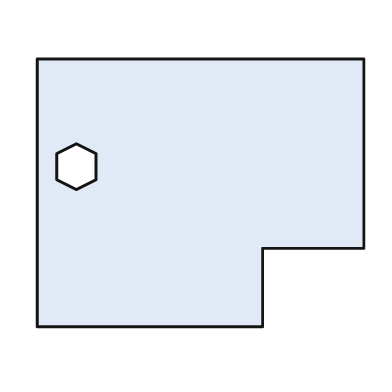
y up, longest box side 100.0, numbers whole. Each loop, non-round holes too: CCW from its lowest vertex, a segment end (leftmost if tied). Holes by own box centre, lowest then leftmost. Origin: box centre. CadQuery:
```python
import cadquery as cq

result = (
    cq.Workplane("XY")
    .moveTo(-50.0, -41.0)
    .lineTo(19.0, -41.0)
    .lineTo(19.0, -17.0)
    .lineTo(50.0, -17.0)
    .lineTo(50.0, 41.0)
    .lineTo(-50.0, 41.0)
    .close()
    .moveTo(-38.0, 1.0)
    .lineTo(-32.0, 4.0)
    .lineTo(-32.0, 12.0)
    .lineTo(-38.0, 15.0)
    .lineTo(-44.0, 12.0)
    .lineTo(-44.0, 4.0)
    .close()
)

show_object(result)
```